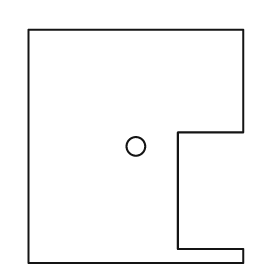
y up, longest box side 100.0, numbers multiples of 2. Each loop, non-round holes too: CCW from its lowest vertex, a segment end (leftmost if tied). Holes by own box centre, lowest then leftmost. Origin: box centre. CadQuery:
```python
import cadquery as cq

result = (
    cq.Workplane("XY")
    .moveTo(-46.0, -50.0)
    .lineTo(46.0, -50.0)
    .lineTo(46.0, -44.0)
    .lineTo(18.0, -44.0)
    .lineTo(18.0, 6.0)
    .lineTo(46.0, 6.0)
    .lineTo(46.0, 50.0)
    .lineTo(-46.0, 50.0)
    .close()
    .moveTo(0.0, 0.0)
    .circle(4.0)
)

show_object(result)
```